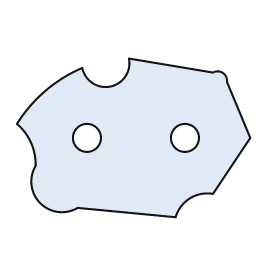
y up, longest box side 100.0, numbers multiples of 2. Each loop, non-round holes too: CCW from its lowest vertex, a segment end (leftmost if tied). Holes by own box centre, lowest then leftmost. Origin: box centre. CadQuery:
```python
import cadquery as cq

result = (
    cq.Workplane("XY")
    .moveTo(18.0, -34.0)
    .threePointArc((24.0, -26.0), (34.0, -24.0))
    .lineTo(50.0, 0.0)
    .lineTo(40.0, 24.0)
    .threePointArc((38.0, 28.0), (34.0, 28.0))
    .lineTo(-2.0, 34.0)
    .threePointArc((-10.0, 22.0), (-22.0, 30.0))
    .threePointArc((-38.0, 20.0), (-50.0, 6.0))
    .threePointArc((-44.0, -2.0), (-42.0, -12.0))
    .threePointArc((-40.0, -28.0), (-24.0, -30.0))
    .close()
    .moveTo(-20.0, 0.0)
    .circle(6.0)
    .moveTo(22.0, 0.0)
    .circle(6.0)
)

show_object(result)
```